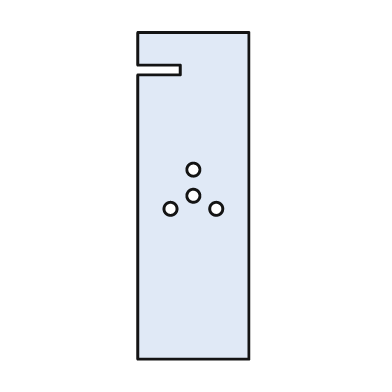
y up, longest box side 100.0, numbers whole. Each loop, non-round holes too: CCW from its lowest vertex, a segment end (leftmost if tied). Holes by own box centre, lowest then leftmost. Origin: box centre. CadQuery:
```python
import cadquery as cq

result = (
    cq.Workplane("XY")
    .moveTo(-17.0, -50.0)
    .lineTo(17.0, -50.0)
    .lineTo(17.0, 50.0)
    .lineTo(-17.0, 50.0)
    .lineTo(-17.0, 40.0)
    .lineTo(-4.0, 40.0)
    .lineTo(-4.0, 37.0)
    .lineTo(-17.0, 37.0)
    .close()
    .moveTo(-7.0, -4.0)
    .circle(2.0)
    .moveTo(7.0, -4.0)
    .circle(2.0)
    .moveTo(0.0, 0.0)
    .circle(2.0)
    .moveTo(0.0, 8.0)
    .circle(2.0)
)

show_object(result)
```